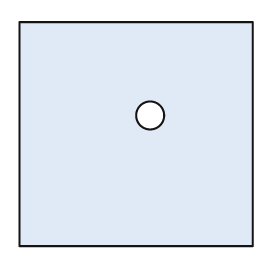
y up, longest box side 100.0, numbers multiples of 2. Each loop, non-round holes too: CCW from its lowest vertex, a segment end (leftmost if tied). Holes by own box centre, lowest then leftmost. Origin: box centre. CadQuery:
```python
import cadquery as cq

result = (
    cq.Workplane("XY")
    .moveTo(-50.0, -48.0)
    .lineTo(50.0, -48.0)
    .lineTo(50.0, 48.0)
    .lineTo(-50.0, 48.0)
    .close()
    .moveTo(6.0, 8.0)
    .circle(6.0)
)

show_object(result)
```